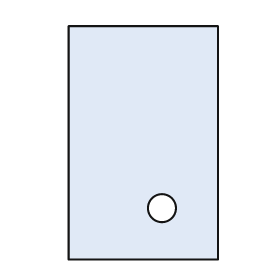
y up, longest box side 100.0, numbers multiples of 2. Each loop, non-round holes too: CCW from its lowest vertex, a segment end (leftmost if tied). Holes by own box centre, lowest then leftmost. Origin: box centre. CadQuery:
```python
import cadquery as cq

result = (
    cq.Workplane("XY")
    .moveTo(-32.0, -50.0)
    .lineTo(32.0, -50.0)
    .lineTo(32.0, 50.0)
    .lineTo(-32.0, 50.0)
    .close()
    .moveTo(8.0, -28.0)
    .circle(6.0)
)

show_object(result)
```